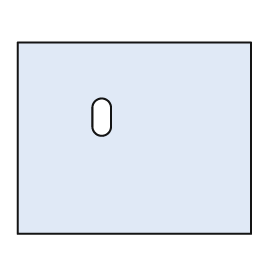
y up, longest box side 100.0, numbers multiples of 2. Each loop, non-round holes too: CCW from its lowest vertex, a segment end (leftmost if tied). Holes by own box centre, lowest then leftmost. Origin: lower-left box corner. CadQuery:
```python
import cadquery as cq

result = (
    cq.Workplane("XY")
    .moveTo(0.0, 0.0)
    .lineTo(100.0, 0.0)
    .lineTo(100.0, 82.0)
    .lineTo(0.0, 82.0)
    .close()
    .moveTo(32.0, 46.0)
    .threePointArc((36.0, 42.0), (40.0, 46.0))
    .lineTo(40.0, 54.0)
    .threePointArc((36.0, 58.0), (32.0, 54.0))
    .close()
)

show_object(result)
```